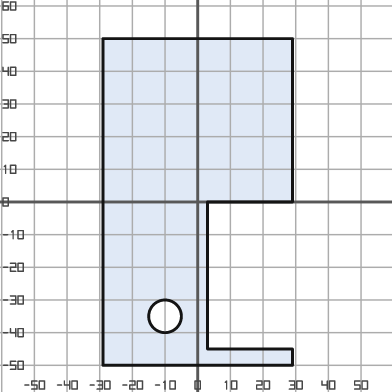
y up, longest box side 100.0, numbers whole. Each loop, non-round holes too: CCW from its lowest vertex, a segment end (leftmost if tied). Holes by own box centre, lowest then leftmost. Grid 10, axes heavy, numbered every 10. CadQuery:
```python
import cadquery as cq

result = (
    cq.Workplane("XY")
    .moveTo(-29.0, -50.0)
    .lineTo(29.0, -50.0)
    .lineTo(29.0, -45.0)
    .lineTo(3.0, -45.0)
    .lineTo(3.0, 0.0)
    .lineTo(29.0, 0.0)
    .lineTo(29.0, 50.0)
    .lineTo(-29.0, 50.0)
    .close()
    .moveTo(-10.0, -35.0)
    .circle(5.0)
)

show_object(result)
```